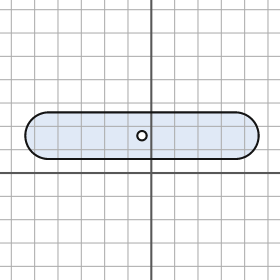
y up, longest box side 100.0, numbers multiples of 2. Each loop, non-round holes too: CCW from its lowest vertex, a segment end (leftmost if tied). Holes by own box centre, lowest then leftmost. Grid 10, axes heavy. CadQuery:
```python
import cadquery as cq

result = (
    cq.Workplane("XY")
    .moveTo(-44.0, 6.0)
    .lineTo(36.0, 6.0)
    .threePointArc((46.0, 16.0), (36.0, 26.0))
    .lineTo(-44.0, 26.0)
    .threePointArc((-54.0, 16.0), (-44.0, 6.0))
    .close()
    .moveTo(-4.0, 16.0)
    .circle(2.0)
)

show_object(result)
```